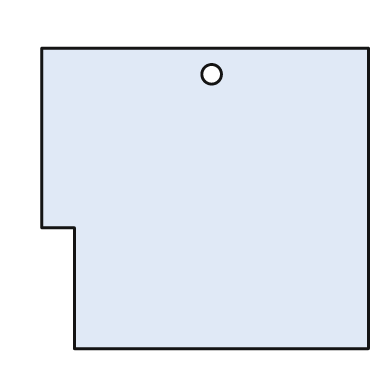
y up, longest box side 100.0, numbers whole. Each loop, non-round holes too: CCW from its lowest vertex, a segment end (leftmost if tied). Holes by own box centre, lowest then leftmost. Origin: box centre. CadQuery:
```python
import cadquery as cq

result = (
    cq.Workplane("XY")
    .moveTo(-40.0, -46.0)
    .lineTo(50.0, -46.0)
    .lineTo(50.0, 46.0)
    .lineTo(-50.0, 46.0)
    .lineTo(-50.0, -9.0)
    .lineTo(-40.0, -9.0)
    .close()
    .moveTo(2.0, 38.0)
    .circle(3.0)
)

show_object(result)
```